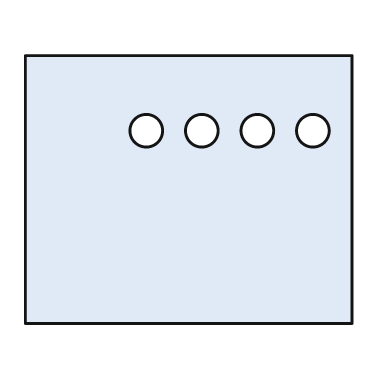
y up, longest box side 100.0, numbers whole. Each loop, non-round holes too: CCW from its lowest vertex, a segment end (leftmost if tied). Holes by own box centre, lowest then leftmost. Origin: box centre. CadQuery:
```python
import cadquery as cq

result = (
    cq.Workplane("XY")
    .moveTo(-50.0, -41.0)
    .lineTo(50.0, -41.0)
    .lineTo(50.0, 41.0)
    .lineTo(-50.0, 41.0)
    .close()
    .moveTo(-13.0, 18.0)
    .circle(5.0)
    .moveTo(4.0, 18.0)
    .circle(5.0)
    .moveTo(21.0, 18.0)
    .circle(5.0)
    .moveTo(38.0, 18.0)
    .circle(5.0)
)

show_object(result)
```